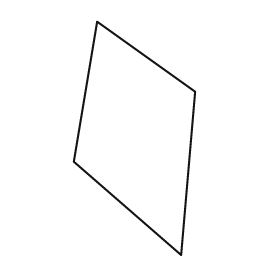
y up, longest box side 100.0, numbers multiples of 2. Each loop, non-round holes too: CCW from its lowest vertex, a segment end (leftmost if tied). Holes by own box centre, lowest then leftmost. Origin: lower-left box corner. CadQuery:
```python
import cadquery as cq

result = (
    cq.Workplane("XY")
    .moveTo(46.0, 0.0)
    .lineTo(52.0, 70.0)
    .lineTo(10.0, 100.0)
    .lineTo(0.0, 40.0)
    .close()
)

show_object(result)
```